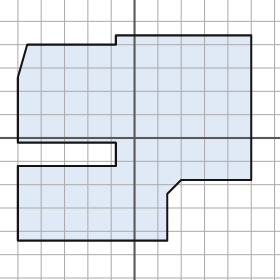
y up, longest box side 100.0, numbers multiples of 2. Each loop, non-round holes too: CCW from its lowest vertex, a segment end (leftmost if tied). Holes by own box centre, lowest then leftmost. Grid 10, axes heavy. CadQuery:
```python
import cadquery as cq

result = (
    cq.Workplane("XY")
    .moveTo(-50.0, -44.0)
    .lineTo(14.0, -44.0)
    .lineTo(14.0, -24.0)
    .lineTo(20.0, -18.0)
    .lineTo(50.0, -18.0)
    .lineTo(50.0, 44.0)
    .lineTo(-8.0, 44.0)
    .lineTo(-8.0, 40.0)
    .lineTo(-46.0, 40.0)
    .lineTo(-50.0, 26.0)
    .lineTo(-50.0, -2.0)
    .lineTo(-8.0, -2.0)
    .lineTo(-8.0, -12.0)
    .lineTo(-50.0, -12.0)
    .close()
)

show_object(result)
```